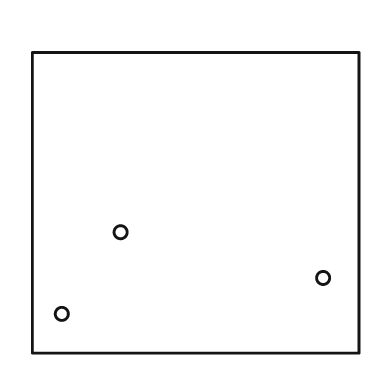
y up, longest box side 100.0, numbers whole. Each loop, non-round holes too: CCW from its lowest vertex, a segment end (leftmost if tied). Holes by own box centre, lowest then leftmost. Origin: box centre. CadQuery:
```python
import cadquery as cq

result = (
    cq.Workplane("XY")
    .moveTo(-50.0, -46.0)
    .lineTo(50.0, -46.0)
    .lineTo(50.0, 46.0)
    .lineTo(-50.0, 46.0)
    .close()
    .moveTo(-41.0, -34.0)
    .circle(2.0)
    .moveTo(39.0, -23.0)
    .circle(2.0)
    .moveTo(-23.0, -9.0)
    .circle(2.0)
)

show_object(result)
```